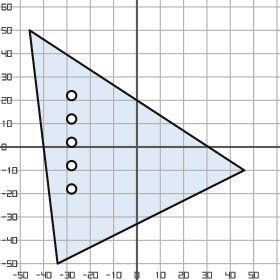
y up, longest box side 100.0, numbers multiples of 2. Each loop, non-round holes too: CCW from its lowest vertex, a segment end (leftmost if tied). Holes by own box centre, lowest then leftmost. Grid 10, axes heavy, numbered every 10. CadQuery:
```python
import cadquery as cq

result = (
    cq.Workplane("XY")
    .moveTo(-34.0, -50.0)
    .lineTo(46.0, -10.0)
    .lineTo(-46.0, 50.0)
    .close()
    .moveTo(-28.0, -18.0)
    .circle(2.0)
    .moveTo(-28.0, -8.0)
    .circle(2.0)
    .moveTo(-28.0, 2.0)
    .circle(2.0)
    .moveTo(-28.0, 12.0)
    .circle(2.0)
    .moveTo(-28.0, 22.0)
    .circle(2.0)
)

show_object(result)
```